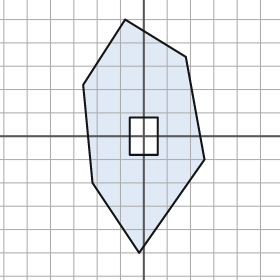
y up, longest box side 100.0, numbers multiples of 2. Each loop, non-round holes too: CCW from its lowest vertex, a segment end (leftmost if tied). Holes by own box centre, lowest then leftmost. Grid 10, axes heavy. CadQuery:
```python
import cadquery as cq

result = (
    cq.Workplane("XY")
    .moveTo(-2.0, -50.0)
    .lineTo(26.0, -10.0)
    .lineTo(18.0, 34.0)
    .lineTo(-8.0, 50.0)
    .lineTo(-26.0, 22.0)
    .lineTo(-22.0, -20.0)
    .close()
    .moveTo(-6.0, -8.0)
    .lineTo(6.0, -8.0)
    .lineTo(6.0, 8.0)
    .lineTo(-6.0, 8.0)
    .close()
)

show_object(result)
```